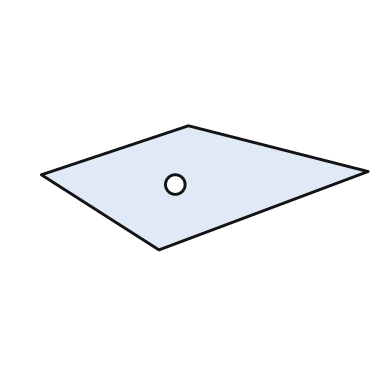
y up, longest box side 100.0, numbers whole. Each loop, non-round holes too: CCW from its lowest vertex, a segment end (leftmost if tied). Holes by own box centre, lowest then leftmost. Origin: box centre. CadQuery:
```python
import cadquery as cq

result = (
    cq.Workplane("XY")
    .moveTo(-14.0, -19.0)
    .lineTo(50.0, 5.0)
    .lineTo(-5.0, 19.0)
    .lineTo(-50.0, 4.0)
    .close()
    .moveTo(-9.0, 1.0)
    .circle(3.0)
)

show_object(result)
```